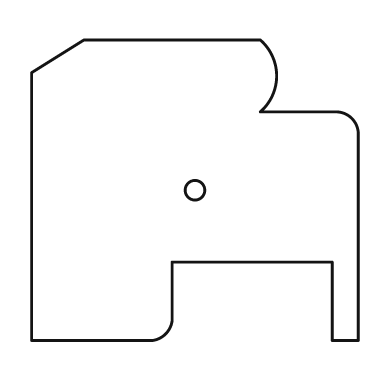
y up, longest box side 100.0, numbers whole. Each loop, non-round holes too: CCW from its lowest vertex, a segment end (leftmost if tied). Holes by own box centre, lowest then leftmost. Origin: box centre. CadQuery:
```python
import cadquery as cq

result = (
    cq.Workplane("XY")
    .moveTo(-50.0, -46.0)
    .lineTo(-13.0, -46.0)
    .threePointArc((-9.0, -44.0), (-7.0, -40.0))
    .lineTo(-7.0, -22.0)
    .lineTo(42.0, -22.0)
    .lineTo(42.0, -46.0)
    .lineTo(50.0, -46.0)
    .lineTo(50.0, 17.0)
    .threePointArc((48.0, 22.0), (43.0, 24.0))
    .lineTo(20.0, 24.0)
    .threePointArc((25.0, 35.0), (20.0, 46.0))
    .lineTo(-34.0, 46.0)
    .lineTo(-50.0, 36.0)
    .close()
    .moveTo(0.0, 0.0)
    .circle(3.0)
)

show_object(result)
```